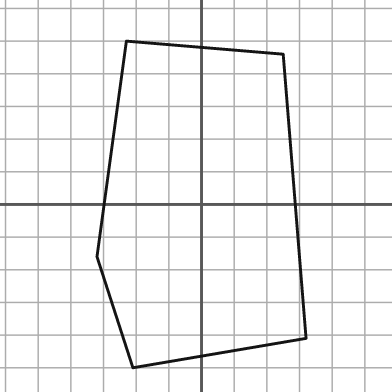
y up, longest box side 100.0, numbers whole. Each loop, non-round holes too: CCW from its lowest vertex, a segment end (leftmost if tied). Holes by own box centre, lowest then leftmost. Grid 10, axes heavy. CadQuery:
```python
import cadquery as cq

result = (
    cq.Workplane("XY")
    .moveTo(-21.0, -50.0)
    .lineTo(32.0, -41.0)
    .lineTo(25.0, 46.0)
    .lineTo(-23.0, 50.0)
    .lineTo(-32.0, -16.0)
    .close()
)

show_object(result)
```